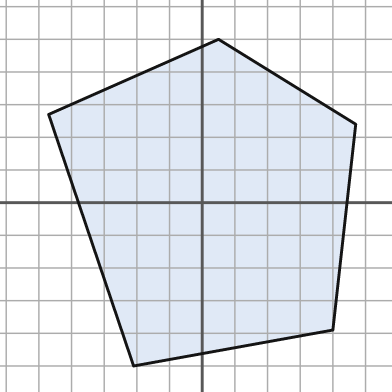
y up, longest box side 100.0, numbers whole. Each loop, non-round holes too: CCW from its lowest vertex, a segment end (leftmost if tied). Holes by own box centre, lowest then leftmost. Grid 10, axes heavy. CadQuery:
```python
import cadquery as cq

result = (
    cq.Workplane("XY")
    .moveTo(-21.0, -50.0)
    .lineTo(40.0, -39.0)
    .lineTo(47.0, 24.0)
    .lineTo(5.0, 50.0)
    .lineTo(-47.0, 27.0)
    .close()
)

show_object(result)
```